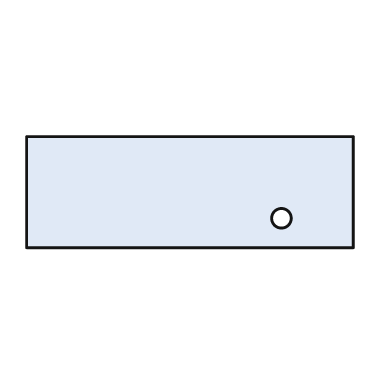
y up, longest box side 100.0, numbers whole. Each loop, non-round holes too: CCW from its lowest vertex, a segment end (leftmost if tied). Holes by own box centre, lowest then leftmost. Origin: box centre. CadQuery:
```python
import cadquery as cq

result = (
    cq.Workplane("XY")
    .moveTo(-50.0, -17.0)
    .lineTo(50.0, -17.0)
    .lineTo(50.0, 17.0)
    .lineTo(-50.0, 17.0)
    .close()
    .moveTo(28.0, -8.0)
    .circle(3.0)
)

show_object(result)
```